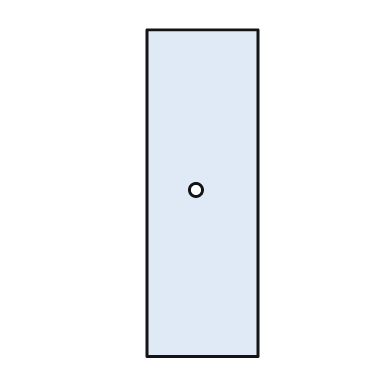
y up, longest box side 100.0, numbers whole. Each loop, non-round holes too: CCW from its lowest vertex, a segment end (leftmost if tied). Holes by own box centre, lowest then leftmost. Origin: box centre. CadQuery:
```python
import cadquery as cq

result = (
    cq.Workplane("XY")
    .moveTo(-17.0, -50.0)
    .lineTo(17.0, -50.0)
    .lineTo(17.0, 50.0)
    .lineTo(-17.0, 50.0)
    .close()
    .moveTo(-2.0, 1.0)
    .circle(2.0)
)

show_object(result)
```